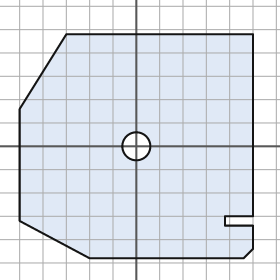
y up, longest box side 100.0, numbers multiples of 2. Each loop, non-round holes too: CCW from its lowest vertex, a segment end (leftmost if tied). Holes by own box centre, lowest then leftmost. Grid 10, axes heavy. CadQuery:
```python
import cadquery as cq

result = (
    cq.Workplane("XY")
    .moveTo(-20.0, -48.0)
    .lineTo(46.0, -48.0)
    .lineTo(50.0, -44.0)
    .lineTo(50.0, -34.0)
    .lineTo(38.0, -34.0)
    .lineTo(38.0, -30.0)
    .lineTo(50.0, -30.0)
    .lineTo(50.0, 48.0)
    .lineTo(-30.0, 48.0)
    .lineTo(-50.0, 16.0)
    .lineTo(-50.0, -32.0)
    .close()
    .moveTo(0.0, 0.0)
    .circle(6.0)
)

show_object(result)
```